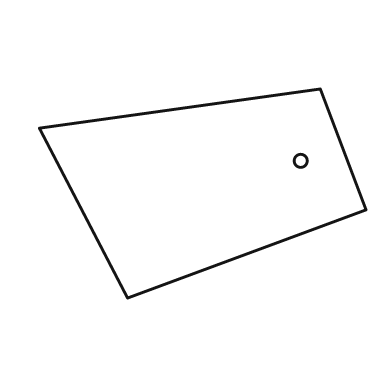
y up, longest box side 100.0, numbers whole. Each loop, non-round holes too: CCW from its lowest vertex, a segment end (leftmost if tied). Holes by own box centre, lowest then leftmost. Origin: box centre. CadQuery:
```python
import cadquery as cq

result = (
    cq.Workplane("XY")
    .moveTo(-23.0, -32.0)
    .lineTo(50.0, -5.0)
    .lineTo(36.0, 32.0)
    .lineTo(-50.0, 20.0)
    .close()
    .moveTo(30.0, 10.0)
    .circle(2.0)
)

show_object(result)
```